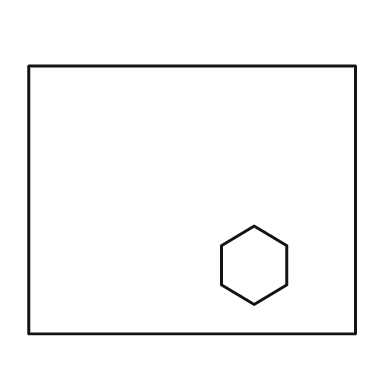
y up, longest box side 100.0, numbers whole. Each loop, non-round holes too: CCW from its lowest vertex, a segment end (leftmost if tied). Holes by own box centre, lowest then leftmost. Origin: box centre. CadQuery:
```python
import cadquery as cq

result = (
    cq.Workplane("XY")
    .moveTo(-50.0, -41.0)
    .lineTo(50.0, -41.0)
    .lineTo(50.0, 41.0)
    .lineTo(-50.0, 41.0)
    .close()
    .moveTo(19.0, -32.0)
    .lineTo(29.0, -26.0)
    .lineTo(29.0, -14.0)
    .lineTo(19.0, -8.0)
    .lineTo(9.0, -14.0)
    .lineTo(9.0, -26.0)
    .close()
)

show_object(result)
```